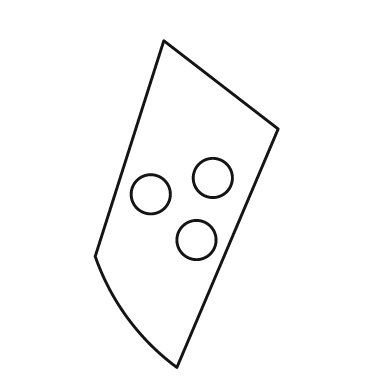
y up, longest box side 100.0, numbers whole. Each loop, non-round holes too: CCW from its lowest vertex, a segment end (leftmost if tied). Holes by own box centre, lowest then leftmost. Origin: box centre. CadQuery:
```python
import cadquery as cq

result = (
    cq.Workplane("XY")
    .moveTo(-3.0, -50.0)
    .lineTo(28.0, 23.0)
    .lineTo(-7.0, 50.0)
    .lineTo(-28.0, -16.0)
    .threePointArc((-18.0, -35.0), (-3.0, -50.0))
    .close()
    .moveTo(3.0, -11.0)
    .circle(6.0)
    .moveTo(-11.0, 3.0)
    .circle(6.0)
    .moveTo(8.0, 8.0)
    .circle(6.0)
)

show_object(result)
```